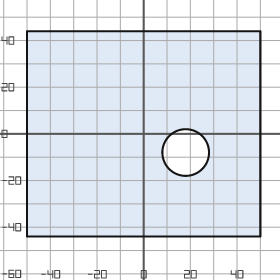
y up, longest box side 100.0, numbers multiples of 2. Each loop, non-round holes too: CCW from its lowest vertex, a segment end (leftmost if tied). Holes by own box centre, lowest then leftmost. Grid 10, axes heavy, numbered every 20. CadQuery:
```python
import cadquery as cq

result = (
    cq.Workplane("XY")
    .moveTo(-50.0, -44.0)
    .lineTo(50.0, -44.0)
    .lineTo(50.0, 44.0)
    .lineTo(-50.0, 44.0)
    .close()
    .moveTo(18.0, -8.0)
    .circle(10.0)
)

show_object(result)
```